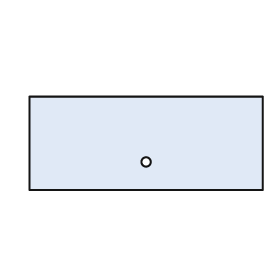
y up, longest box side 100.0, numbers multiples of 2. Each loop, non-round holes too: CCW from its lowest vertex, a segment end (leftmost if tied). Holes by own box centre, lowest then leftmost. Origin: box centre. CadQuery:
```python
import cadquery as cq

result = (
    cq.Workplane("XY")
    .moveTo(-50.0, -20.0)
    .lineTo(50.0, -20.0)
    .lineTo(50.0, 20.0)
    .lineTo(-50.0, 20.0)
    .close()
    .moveTo(0.0, -8.0)
    .circle(2.0)
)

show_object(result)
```